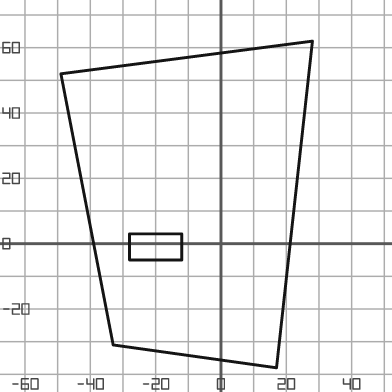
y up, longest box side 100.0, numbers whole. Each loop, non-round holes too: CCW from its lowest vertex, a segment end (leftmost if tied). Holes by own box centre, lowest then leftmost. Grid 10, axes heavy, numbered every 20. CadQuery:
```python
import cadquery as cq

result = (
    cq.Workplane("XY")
    .moveTo(17.0, -38.0)
    .lineTo(28.0, 62.0)
    .lineTo(-49.0, 52.0)
    .lineTo(-33.0, -31.0)
    .close()
    .moveTo(-28.0, -5.0)
    .lineTo(-12.0, -5.0)
    .lineTo(-12.0, 3.0)
    .lineTo(-28.0, 3.0)
    .close()
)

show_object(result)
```